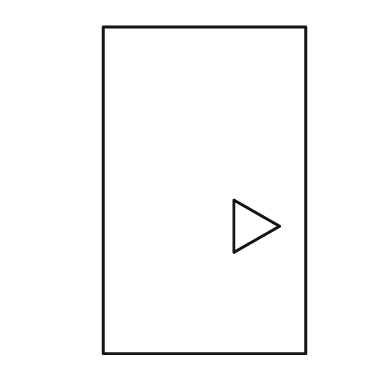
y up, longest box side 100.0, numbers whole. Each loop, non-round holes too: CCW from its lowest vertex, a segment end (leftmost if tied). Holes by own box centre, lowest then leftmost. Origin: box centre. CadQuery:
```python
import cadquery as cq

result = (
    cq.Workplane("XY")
    .moveTo(-31.0, -50.0)
    .lineTo(31.0, -50.0)
    .lineTo(31.0, 50.0)
    .lineTo(-31.0, 50.0)
    .close()
    .moveTo(9.0, -19.0)
    .lineTo(23.0, -11.0)
    .lineTo(9.0, -3.0)
    .close()
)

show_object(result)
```